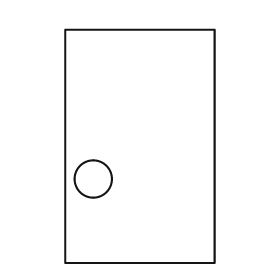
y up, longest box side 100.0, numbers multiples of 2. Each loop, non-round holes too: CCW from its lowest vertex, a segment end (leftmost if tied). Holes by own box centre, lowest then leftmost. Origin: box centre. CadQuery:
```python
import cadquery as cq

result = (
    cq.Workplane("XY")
    .moveTo(-32.0, -50.0)
    .lineTo(32.0, -50.0)
    .lineTo(32.0, 50.0)
    .lineTo(-32.0, 50.0)
    .close()
    .moveTo(-20.0, -14.0)
    .circle(8.0)
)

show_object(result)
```